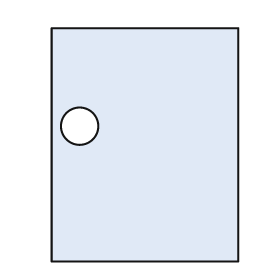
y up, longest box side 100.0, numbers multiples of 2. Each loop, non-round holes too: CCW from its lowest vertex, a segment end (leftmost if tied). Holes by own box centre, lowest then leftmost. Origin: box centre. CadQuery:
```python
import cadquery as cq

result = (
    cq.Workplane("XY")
    .moveTo(-40.0, -50.0)
    .lineTo(40.0, -50.0)
    .lineTo(40.0, 50.0)
    .lineTo(-40.0, 50.0)
    .close()
    .moveTo(-28.0, 8.0)
    .circle(8.0)
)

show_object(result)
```